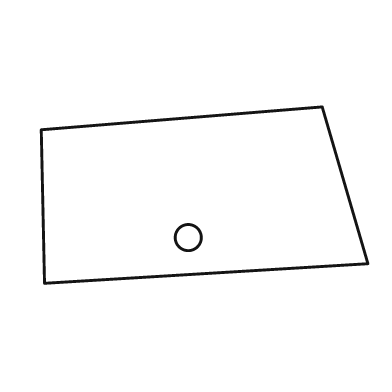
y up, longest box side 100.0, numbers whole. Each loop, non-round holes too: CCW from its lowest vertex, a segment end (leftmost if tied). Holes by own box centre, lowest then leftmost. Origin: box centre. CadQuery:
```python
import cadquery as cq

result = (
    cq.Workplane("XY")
    .moveTo(-49.0, -27.0)
    .lineTo(50.0, -21.0)
    .lineTo(36.0, 27.0)
    .lineTo(-50.0, 20.0)
    .close()
    .moveTo(-5.0, -13.0)
    .circle(4.0)
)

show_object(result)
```